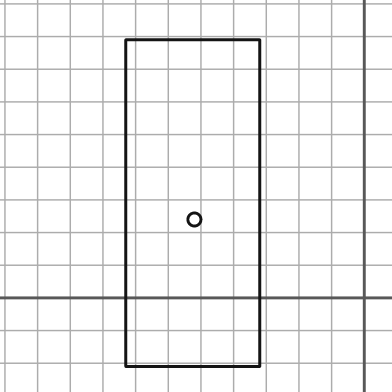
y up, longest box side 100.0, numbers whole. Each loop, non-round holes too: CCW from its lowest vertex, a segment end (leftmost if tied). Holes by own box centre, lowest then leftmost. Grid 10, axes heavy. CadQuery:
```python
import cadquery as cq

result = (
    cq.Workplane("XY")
    .moveTo(-73.0, -21.0)
    .lineTo(-32.0, -21.0)
    .lineTo(-32.0, 79.0)
    .lineTo(-73.0, 79.0)
    .close()
    .moveTo(-52.0, 24.0)
    .circle(2.0)
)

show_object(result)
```